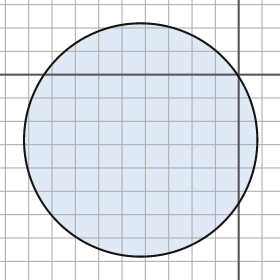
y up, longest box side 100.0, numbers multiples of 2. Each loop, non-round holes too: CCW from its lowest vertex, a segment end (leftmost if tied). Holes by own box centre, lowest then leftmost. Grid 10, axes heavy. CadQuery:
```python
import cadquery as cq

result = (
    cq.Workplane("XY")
    .moveTo(-42.0, -28.0)
    .circle(50.0)
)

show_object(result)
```